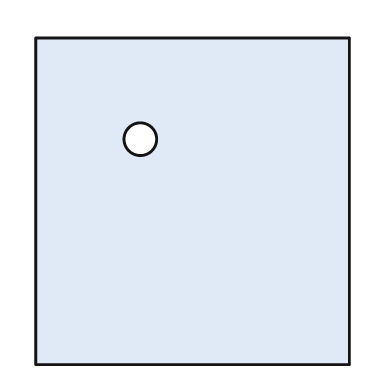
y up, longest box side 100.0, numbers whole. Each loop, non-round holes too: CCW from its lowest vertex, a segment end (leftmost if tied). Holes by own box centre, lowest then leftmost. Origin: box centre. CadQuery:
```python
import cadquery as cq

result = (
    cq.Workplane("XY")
    .moveTo(-48.0, -50.0)
    .lineTo(48.0, -50.0)
    .lineTo(48.0, 50.0)
    .lineTo(-48.0, 50.0)
    .close()
    .moveTo(-16.0, 19.0)
    .circle(5.0)
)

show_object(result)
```